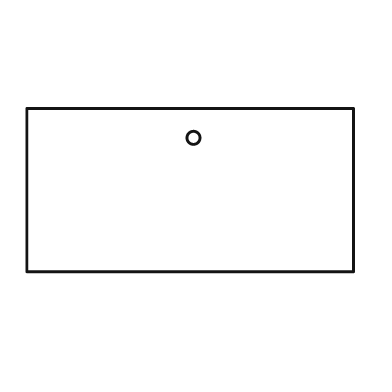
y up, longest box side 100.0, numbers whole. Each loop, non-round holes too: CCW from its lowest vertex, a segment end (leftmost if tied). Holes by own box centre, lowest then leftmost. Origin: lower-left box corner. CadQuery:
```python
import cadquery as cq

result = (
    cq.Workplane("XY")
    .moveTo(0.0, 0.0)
    .lineTo(100.0, 0.0)
    .lineTo(100.0, 50.0)
    .lineTo(0.0, 50.0)
    .close()
    .moveTo(51.0, 41.0)
    .circle(2.0)
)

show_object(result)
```